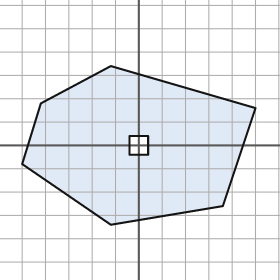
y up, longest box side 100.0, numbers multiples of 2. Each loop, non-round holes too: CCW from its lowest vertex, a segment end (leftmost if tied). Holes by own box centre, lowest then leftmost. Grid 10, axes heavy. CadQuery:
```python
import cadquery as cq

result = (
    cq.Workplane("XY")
    .moveTo(-12.0, -34.0)
    .lineTo(36.0, -26.0)
    .lineTo(50.0, 16.0)
    .lineTo(-12.0, 34.0)
    .lineTo(-42.0, 18.0)
    .lineTo(-50.0, -8.0)
    .close()
    .moveTo(-4.0, -4.0)
    .lineTo(4.0, -4.0)
    .lineTo(4.0, 4.0)
    .lineTo(-4.0, 4.0)
    .close()
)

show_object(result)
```